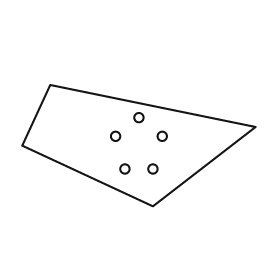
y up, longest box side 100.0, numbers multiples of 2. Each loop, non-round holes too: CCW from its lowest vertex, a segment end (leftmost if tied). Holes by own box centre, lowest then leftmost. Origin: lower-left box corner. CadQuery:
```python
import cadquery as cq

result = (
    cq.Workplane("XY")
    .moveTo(56.0, 0.0)
    .lineTo(100.0, 34.0)
    .lineTo(12.0, 52.0)
    .lineTo(0.0, 26.0)
    .close()
    .moveTo(44.0, 16.0)
    .circle(2.0)
    .moveTo(56.0, 16.0)
    .circle(2.0)
    .moveTo(40.0, 30.0)
    .circle(2.0)
    .moveTo(60.0, 30.0)
    .circle(2.0)
    .moveTo(50.0, 38.0)
    .circle(2.0)
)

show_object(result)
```